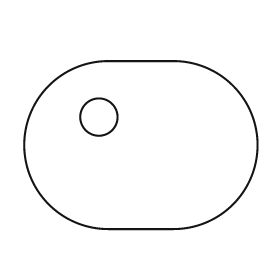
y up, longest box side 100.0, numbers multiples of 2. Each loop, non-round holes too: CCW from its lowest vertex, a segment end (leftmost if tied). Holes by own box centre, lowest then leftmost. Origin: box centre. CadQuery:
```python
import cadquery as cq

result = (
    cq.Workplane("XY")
    .moveTo(-14.0, -36.0)
    .lineTo(14.0, -36.0)
    .threePointArc((50.0, 0.0), (14.0, 36.0))
    .lineTo(-14.0, 36.0)
    .threePointArc((-50.0, 0.0), (-14.0, -36.0))
    .close()
    .moveTo(-18.0, 12.0)
    .circle(8.0)
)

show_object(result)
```